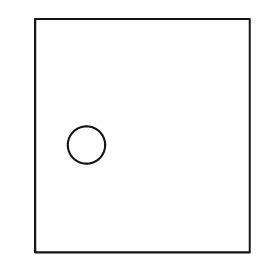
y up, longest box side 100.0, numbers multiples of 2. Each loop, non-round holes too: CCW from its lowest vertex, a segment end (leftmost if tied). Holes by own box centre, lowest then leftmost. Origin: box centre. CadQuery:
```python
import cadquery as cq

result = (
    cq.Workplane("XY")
    .moveTo(-46.0, -50.0)
    .lineTo(46.0, -50.0)
    .lineTo(46.0, 50.0)
    .lineTo(-46.0, 50.0)
    .close()
    .moveTo(-24.0, -4.0)
    .circle(8.0)
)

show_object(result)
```